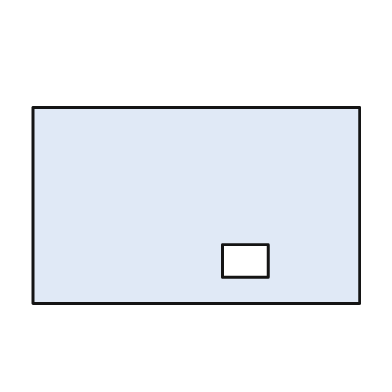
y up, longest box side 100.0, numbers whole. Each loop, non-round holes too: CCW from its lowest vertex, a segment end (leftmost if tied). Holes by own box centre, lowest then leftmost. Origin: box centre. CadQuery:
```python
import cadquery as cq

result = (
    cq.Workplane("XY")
    .moveTo(-50.0, -30.0)
    .lineTo(50.0, -30.0)
    .lineTo(50.0, 30.0)
    .lineTo(-50.0, 30.0)
    .close()
    .moveTo(8.0, -22.0)
    .lineTo(22.0, -22.0)
    .lineTo(22.0, -12.0)
    .lineTo(8.0, -12.0)
    .close()
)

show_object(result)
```